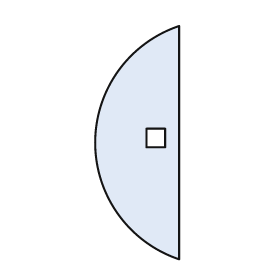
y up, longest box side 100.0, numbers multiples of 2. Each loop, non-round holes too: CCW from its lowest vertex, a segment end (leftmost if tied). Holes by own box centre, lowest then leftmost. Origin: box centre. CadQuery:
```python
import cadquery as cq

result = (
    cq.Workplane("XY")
    .moveTo(18.0, -50.0)
    .lineTo(18.0, 50.0)
    .threePointArc((-18.0, 0.0), (18.0, -50.0))
    .close()
    .moveTo(4.0, -2.0)
    .lineTo(12.0, -2.0)
    .lineTo(12.0, 6.0)
    .lineTo(4.0, 6.0)
    .close()
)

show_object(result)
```